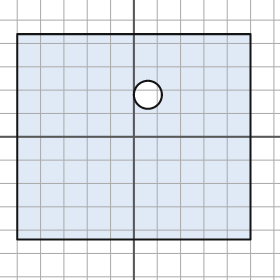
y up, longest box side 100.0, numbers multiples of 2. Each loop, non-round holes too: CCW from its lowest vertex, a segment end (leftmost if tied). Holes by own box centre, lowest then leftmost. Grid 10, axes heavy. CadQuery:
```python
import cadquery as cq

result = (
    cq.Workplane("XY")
    .moveTo(-50.0, -44.0)
    .lineTo(50.0, -44.0)
    .lineTo(50.0, 44.0)
    .lineTo(-50.0, 44.0)
    .close()
    .moveTo(6.0, 18.0)
    .circle(6.0)
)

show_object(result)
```